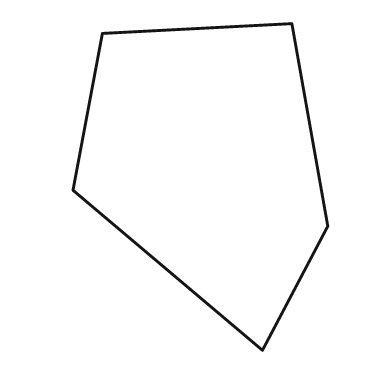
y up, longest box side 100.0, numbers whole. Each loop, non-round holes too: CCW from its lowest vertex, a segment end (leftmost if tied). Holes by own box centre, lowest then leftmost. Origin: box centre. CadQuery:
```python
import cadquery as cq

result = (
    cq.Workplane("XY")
    .moveTo(19.0, -50.0)
    .lineTo(39.0, -12.0)
    .lineTo(28.0, 50.0)
    .lineTo(-30.0, 47.0)
    .lineTo(-39.0, -1.0)
    .close()
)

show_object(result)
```